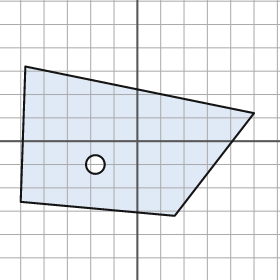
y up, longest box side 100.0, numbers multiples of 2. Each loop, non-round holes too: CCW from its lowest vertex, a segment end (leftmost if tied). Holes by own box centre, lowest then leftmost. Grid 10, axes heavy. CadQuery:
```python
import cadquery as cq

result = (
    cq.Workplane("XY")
    .moveTo(16.0, -32.0)
    .lineTo(50.0, 12.0)
    .lineTo(-48.0, 32.0)
    .lineTo(-50.0, -26.0)
    .close()
    .moveTo(-18.0, -10.0)
    .circle(4.0)
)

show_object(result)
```